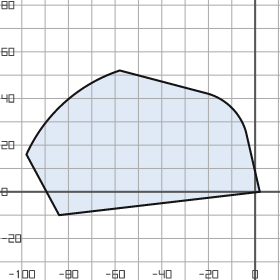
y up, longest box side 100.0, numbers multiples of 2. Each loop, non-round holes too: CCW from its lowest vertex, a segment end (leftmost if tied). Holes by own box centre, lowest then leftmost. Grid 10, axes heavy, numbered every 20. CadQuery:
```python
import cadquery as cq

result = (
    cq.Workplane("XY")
    .moveTo(-84.0, -10.0)
    .lineTo(2.0, 0.0)
    .lineTo(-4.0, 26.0)
    .threePointArc((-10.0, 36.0), (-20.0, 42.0))
    .lineTo(-58.0, 52.0)
    .threePointArc((-82.0, 38.0), (-98.0, 16.0))
    .close()
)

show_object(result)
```